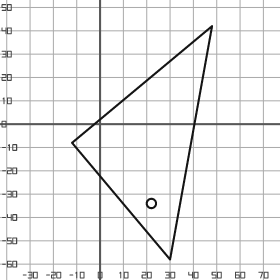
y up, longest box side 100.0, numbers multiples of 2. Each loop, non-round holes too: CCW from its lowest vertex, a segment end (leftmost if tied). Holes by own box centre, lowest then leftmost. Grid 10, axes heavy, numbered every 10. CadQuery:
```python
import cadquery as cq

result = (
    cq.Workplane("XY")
    .moveTo(30.0, -58.0)
    .lineTo(48.0, 42.0)
    .lineTo(-12.0, -8.0)
    .close()
    .moveTo(22.0, -34.0)
    .circle(2.0)
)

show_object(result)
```